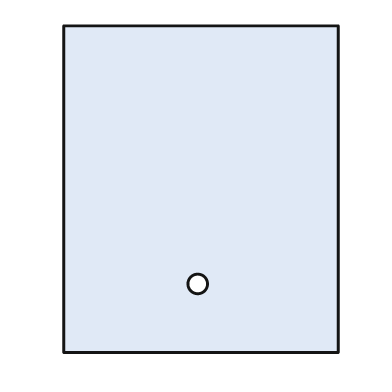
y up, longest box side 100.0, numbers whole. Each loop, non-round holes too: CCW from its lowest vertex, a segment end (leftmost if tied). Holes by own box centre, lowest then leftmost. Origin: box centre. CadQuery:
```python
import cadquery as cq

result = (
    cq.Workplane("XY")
    .moveTo(-42.0, -50.0)
    .lineTo(42.0, -50.0)
    .lineTo(42.0, 50.0)
    .lineTo(-42.0, 50.0)
    .close()
    .moveTo(-1.0, -29.0)
    .circle(3.0)
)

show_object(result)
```